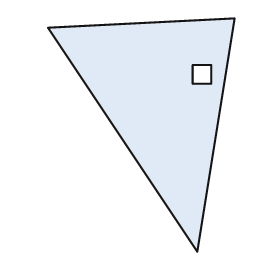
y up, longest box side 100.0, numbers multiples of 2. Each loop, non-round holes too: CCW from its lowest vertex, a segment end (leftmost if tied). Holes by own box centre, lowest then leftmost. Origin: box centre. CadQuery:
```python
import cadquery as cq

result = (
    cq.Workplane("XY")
    .moveTo(24.0, -50.0)
    .lineTo(40.0, 50.0)
    .lineTo(-40.0, 46.0)
    .close()
    .moveTo(22.0, 22.0)
    .lineTo(30.0, 22.0)
    .lineTo(30.0, 30.0)
    .lineTo(22.0, 30.0)
    .close()
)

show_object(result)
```